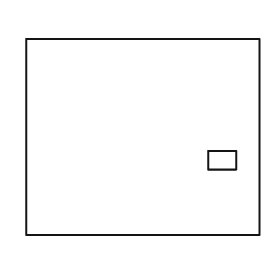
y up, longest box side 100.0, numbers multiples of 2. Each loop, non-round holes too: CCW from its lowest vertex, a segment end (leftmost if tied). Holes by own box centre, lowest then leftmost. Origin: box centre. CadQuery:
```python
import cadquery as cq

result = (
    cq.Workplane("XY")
    .moveTo(-50.0, -42.0)
    .lineTo(50.0, -42.0)
    .lineTo(50.0, 42.0)
    .lineTo(-50.0, 42.0)
    .close()
    .moveTo(28.0, -14.0)
    .lineTo(40.0, -14.0)
    .lineTo(40.0, -6.0)
    .lineTo(28.0, -6.0)
    .close()
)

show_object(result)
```